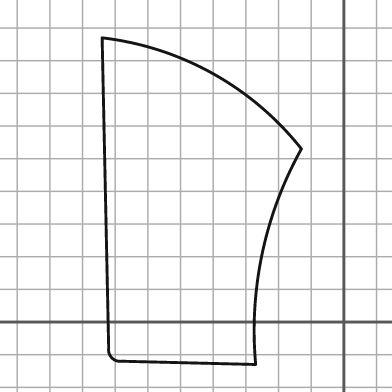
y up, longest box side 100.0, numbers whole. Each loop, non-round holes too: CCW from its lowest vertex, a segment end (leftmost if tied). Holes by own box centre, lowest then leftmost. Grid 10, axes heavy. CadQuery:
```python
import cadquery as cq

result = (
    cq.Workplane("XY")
    .moveTo(-27.0, -13.0)
    .threePointArc((-25.0, 21.0), (-13.0, 53.0))
    .threePointArc((-40.0, 76.0), (-74.0, 87.0))
    .lineTo(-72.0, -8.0)
    .threePointArc((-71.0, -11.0), (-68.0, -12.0))
    .close()
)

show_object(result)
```